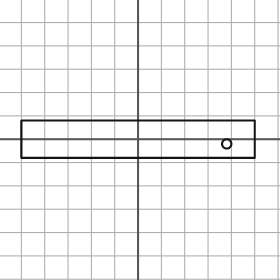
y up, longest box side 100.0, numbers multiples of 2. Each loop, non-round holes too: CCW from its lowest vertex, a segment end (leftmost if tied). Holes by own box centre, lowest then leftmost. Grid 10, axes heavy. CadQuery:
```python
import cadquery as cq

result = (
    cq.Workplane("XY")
    .moveTo(-50.0, -8.0)
    .lineTo(50.0, -8.0)
    .lineTo(50.0, 8.0)
    .lineTo(-50.0, 8.0)
    .close()
    .moveTo(38.0, -2.0)
    .circle(2.0)
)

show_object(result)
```